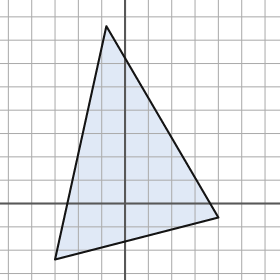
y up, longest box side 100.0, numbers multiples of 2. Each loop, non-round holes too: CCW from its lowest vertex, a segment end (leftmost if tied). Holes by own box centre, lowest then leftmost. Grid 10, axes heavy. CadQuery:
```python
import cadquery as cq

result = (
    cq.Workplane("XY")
    .moveTo(-30.0, -24.0)
    .lineTo(40.0, -6.0)
    .lineTo(-8.0, 76.0)
    .close()
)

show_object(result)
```